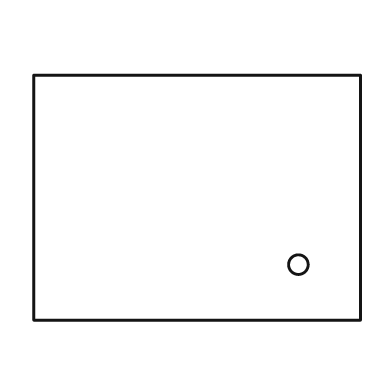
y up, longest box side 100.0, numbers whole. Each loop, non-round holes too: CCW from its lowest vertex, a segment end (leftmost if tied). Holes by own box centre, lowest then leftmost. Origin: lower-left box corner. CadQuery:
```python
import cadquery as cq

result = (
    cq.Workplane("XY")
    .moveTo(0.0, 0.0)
    .lineTo(100.0, 0.0)
    .lineTo(100.0, 75.0)
    .lineTo(0.0, 75.0)
    .close()
    .moveTo(81.0, 17.0)
    .circle(3.0)
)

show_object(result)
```